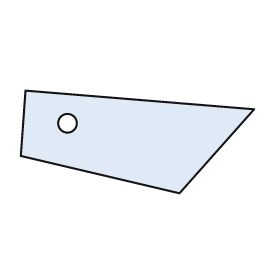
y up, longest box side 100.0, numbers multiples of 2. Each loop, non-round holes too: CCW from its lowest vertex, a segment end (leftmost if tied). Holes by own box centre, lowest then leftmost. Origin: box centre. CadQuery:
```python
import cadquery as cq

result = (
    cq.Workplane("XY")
    .moveTo(18.0, -22.0)
    .lineTo(50.0, 14.0)
    .lineTo(-48.0, 22.0)
    .lineTo(-50.0, -6.0)
    .close()
    .moveTo(-30.0, 8.0)
    .circle(4.0)
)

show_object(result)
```